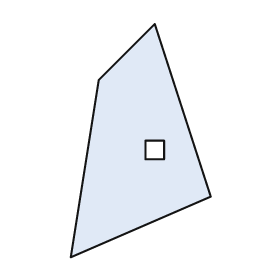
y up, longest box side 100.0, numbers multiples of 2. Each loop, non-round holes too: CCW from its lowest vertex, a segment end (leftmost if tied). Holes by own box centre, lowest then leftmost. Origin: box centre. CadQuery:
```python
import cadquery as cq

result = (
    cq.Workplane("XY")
    .moveTo(-30.0, -50.0)
    .lineTo(30.0, -24.0)
    .lineTo(6.0, 50.0)
    .lineTo(-18.0, 26.0)
    .close()
    .moveTo(2.0, -8.0)
    .lineTo(10.0, -8.0)
    .lineTo(10.0, 0.0)
    .lineTo(2.0, 0.0)
    .close()
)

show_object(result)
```